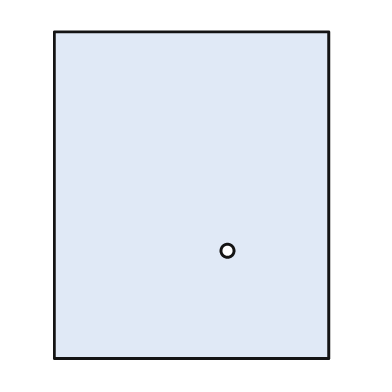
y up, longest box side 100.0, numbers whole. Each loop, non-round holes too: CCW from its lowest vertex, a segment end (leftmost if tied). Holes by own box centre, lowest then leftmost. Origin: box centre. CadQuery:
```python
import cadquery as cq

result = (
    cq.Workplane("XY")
    .moveTo(-42.0, -50.0)
    .lineTo(42.0, -50.0)
    .lineTo(42.0, 50.0)
    .lineTo(-42.0, 50.0)
    .close()
    .moveTo(11.0, -17.0)
    .circle(2.0)
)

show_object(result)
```